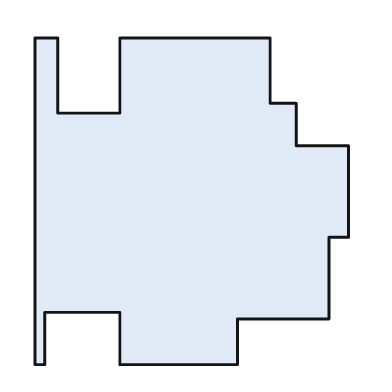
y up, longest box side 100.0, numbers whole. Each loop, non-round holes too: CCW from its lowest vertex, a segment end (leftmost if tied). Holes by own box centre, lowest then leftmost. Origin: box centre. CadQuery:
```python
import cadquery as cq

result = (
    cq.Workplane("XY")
    .moveTo(-48.0, -50.0)
    .lineTo(-45.0, -50.0)
    .lineTo(-45.0, -34.0)
    .lineTo(-22.0, -34.0)
    .lineTo(-22.0, -50.0)
    .lineTo(14.0, -50.0)
    .lineTo(14.0, -36.0)
    .lineTo(42.0, -36.0)
    .lineTo(42.0, -11.0)
    .lineTo(48.0, -11.0)
    .lineTo(48.0, 17.0)
    .lineTo(32.0, 17.0)
    .lineTo(32.0, 30.0)
    .lineTo(24.0, 30.0)
    .lineTo(24.0, 50.0)
    .lineTo(-22.0, 50.0)
    .lineTo(-22.0, 27.0)
    .lineTo(-41.0, 27.0)
    .lineTo(-41.0, 50.0)
    .lineTo(-48.0, 50.0)
    .close()
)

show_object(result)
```